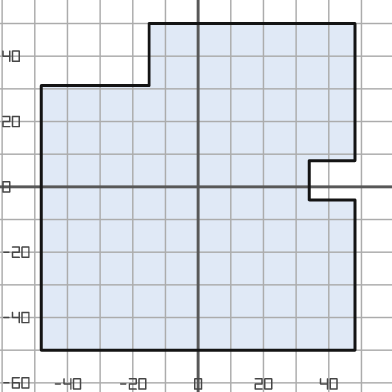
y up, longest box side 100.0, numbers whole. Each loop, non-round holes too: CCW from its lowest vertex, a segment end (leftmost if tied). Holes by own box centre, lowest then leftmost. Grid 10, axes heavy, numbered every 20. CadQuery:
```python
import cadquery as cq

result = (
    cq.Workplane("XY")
    .moveTo(-48.0, -50.0)
    .lineTo(48.0, -50.0)
    .lineTo(48.0, -4.0)
    .lineTo(34.0, -4.0)
    .lineTo(34.0, 8.0)
    .lineTo(48.0, 8.0)
    .lineTo(48.0, 50.0)
    .lineTo(-15.0, 50.0)
    .lineTo(-15.0, 31.0)
    .lineTo(-48.0, 31.0)
    .close()
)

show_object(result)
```